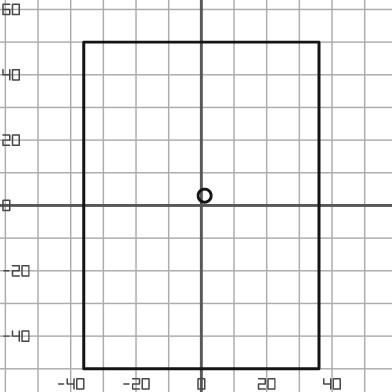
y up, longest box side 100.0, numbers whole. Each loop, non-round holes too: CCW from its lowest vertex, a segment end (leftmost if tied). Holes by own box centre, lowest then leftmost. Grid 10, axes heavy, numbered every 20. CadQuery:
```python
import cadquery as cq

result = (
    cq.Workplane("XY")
    .moveTo(-36.0, -50.0)
    .lineTo(36.0, -50.0)
    .lineTo(36.0, 50.0)
    .lineTo(-36.0, 50.0)
    .close()
    .moveTo(1.0, 3.0)
    .circle(2.0)
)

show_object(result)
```